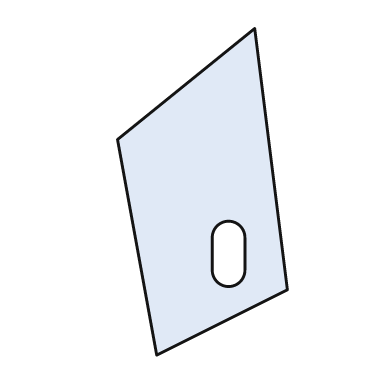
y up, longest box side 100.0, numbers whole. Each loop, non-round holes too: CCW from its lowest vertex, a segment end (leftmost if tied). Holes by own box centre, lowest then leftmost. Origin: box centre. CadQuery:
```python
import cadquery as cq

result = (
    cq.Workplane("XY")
    .moveTo(-14.0, -50.0)
    .lineTo(26.0, -30.0)
    .lineTo(16.0, 50.0)
    .lineTo(-26.0, 16.0)
    .close()
    .moveTo(3.0, -24.0)
    .threePointArc((8.0, -29.0), (13.0, -24.0))
    .lineTo(13.0, -14.0)
    .threePointArc((8.0, -9.0), (3.0, -14.0))
    .close()
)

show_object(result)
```